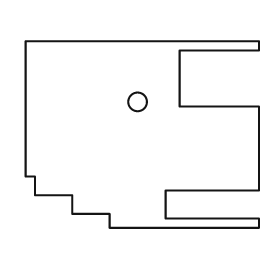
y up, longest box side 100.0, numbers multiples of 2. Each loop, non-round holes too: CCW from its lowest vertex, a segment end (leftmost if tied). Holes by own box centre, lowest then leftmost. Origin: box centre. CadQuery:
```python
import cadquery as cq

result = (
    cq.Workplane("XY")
    .moveTo(-14.0, -40.0)
    .lineTo(50.0, -40.0)
    .lineTo(50.0, -36.0)
    .lineTo(10.0, -36.0)
    .lineTo(10.0, -24.0)
    .lineTo(50.0, -24.0)
    .lineTo(50.0, 12.0)
    .lineTo(16.0, 12.0)
    .lineTo(16.0, 36.0)
    .lineTo(50.0, 36.0)
    .lineTo(50.0, 40.0)
    .lineTo(-50.0, 40.0)
    .lineTo(-50.0, -18.0)
    .lineTo(-46.0, -18.0)
    .lineTo(-46.0, -26.0)
    .lineTo(-30.0, -26.0)
    .lineTo(-30.0, -34.0)
    .lineTo(-14.0, -34.0)
    .close()
    .moveTo(-2.0, 14.0)
    .circle(4.0)
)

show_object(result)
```